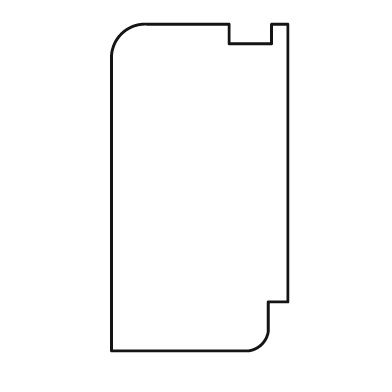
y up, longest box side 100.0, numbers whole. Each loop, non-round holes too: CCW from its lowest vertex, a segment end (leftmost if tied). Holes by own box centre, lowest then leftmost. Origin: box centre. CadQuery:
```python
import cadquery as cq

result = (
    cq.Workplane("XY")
    .moveTo(-27.0, -50.0)
    .lineTo(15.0, -50.0)
    .threePointArc((19.0, -48.0), (21.0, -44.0))
    .lineTo(21.0, -35.0)
    .lineTo(27.0, -35.0)
    .lineTo(27.0, 50.0)
    .lineTo(22.0, 50.0)
    .lineTo(22.0, 44.0)
    .lineTo(9.0, 44.0)
    .lineTo(9.0, 50.0)
    .lineTo(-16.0, 50.0)
    .threePointArc((-24.0, 47.0), (-27.0, 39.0))
    .close()
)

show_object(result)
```